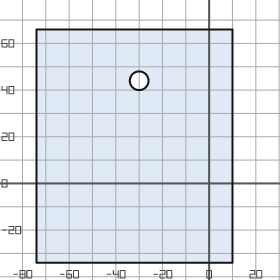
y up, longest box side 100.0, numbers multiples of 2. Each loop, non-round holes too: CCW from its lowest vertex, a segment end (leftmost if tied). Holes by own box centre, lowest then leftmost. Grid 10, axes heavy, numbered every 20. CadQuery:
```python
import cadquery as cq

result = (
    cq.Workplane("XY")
    .moveTo(-74.0, -34.0)
    .lineTo(10.0, -34.0)
    .lineTo(10.0, 66.0)
    .lineTo(-74.0, 66.0)
    .close()
    .moveTo(-30.0, 44.0)
    .circle(4.0)
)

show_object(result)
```